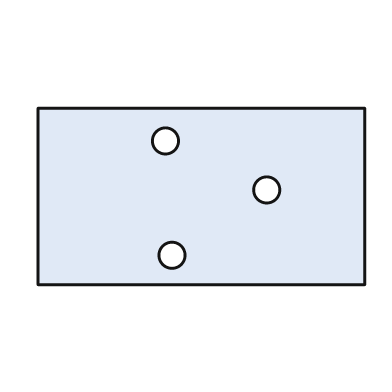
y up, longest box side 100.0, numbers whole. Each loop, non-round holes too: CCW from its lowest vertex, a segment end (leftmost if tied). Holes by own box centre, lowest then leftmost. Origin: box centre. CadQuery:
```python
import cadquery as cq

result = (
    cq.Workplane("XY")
    .moveTo(-50.0, -27.0)
    .lineTo(50.0, -27.0)
    .lineTo(50.0, 27.0)
    .lineTo(-50.0, 27.0)
    .close()
    .moveTo(-9.0, -18.0)
    .circle(4.0)
    .moveTo(20.0, 2.0)
    .circle(4.0)
    .moveTo(-11.0, 17.0)
    .circle(4.0)
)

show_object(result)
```